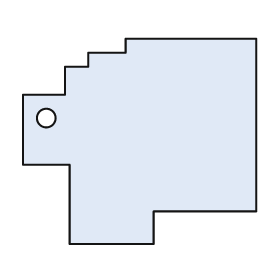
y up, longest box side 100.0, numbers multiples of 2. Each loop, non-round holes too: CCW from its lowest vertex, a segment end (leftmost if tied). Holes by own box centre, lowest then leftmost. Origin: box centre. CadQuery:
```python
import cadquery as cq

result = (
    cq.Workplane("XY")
    .moveTo(-30.0, -44.0)
    .lineTo(6.0, -44.0)
    .lineTo(6.0, -30.0)
    .lineTo(50.0, -30.0)
    .lineTo(50.0, 44.0)
    .lineTo(-6.0, 44.0)
    .lineTo(-6.0, 38.0)
    .lineTo(-22.0, 38.0)
    .lineTo(-22.0, 32.0)
    .lineTo(-32.0, 32.0)
    .lineTo(-32.0, 20.0)
    .lineTo(-50.0, 20.0)
    .lineTo(-50.0, -10.0)
    .lineTo(-30.0, -10.0)
    .close()
    .moveTo(-40.0, 10.0)
    .circle(4.0)
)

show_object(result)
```